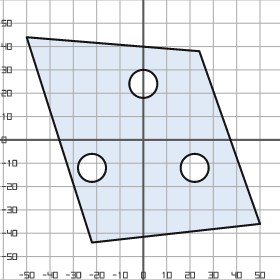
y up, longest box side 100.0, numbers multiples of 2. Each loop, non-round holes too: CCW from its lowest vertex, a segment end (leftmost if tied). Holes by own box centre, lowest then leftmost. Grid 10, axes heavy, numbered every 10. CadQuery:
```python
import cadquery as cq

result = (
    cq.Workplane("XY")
    .moveTo(-22.0, -44.0)
    .lineTo(50.0, -36.0)
    .lineTo(24.0, 38.0)
    .lineTo(-50.0, 44.0)
    .close()
    .moveTo(-22.0, -12.0)
    .circle(6.0)
    .moveTo(22.0, -12.0)
    .circle(6.0)
    .moveTo(0.0, 24.0)
    .circle(6.0)
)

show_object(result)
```